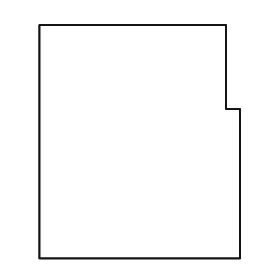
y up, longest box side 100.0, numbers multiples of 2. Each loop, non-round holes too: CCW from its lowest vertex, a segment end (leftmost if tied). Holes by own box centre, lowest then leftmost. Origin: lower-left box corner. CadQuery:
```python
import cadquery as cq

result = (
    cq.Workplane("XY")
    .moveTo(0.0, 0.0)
    .lineTo(86.0, 0.0)
    .lineTo(86.0, 64.0)
    .lineTo(80.0, 64.0)
    .lineTo(80.0, 100.0)
    .lineTo(0.0, 100.0)
    .close()
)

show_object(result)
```